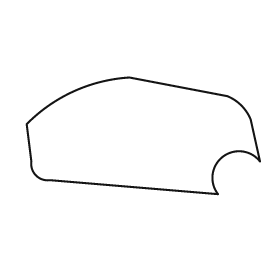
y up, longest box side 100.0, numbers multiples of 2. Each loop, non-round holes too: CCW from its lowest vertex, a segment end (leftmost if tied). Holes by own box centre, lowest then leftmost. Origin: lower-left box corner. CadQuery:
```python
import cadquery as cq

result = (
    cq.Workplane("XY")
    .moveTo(82.0, 0.0)
    .threePointArc((84.0, 16.0), (100.0, 14.0))
    .lineTo(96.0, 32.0)
    .threePointArc((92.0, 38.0), (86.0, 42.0))
    .lineTo(44.0, 50.0)
    .threePointArc((20.0, 44.0), (0.0, 30.0))
    .lineTo(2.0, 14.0)
    .threePointArc((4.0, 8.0), (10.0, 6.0))
    .close()
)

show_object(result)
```